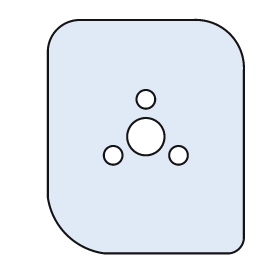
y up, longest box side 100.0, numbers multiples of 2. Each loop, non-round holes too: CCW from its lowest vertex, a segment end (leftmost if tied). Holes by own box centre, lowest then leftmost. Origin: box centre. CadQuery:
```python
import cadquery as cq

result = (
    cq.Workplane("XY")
    .moveTo(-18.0, -50.0)
    .lineTo(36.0, -50.0)
    .threePointArc((40.0, -48.0), (42.0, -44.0))
    .lineTo(42.0, 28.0)
    .threePointArc((36.0, 44.0), (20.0, 50.0))
    .lineTo(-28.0, 50.0)
    .threePointArc((-38.0, 46.0), (-42.0, 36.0))
    .lineTo(-42.0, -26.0)
    .threePointArc((-34.0, -42.0), (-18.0, -50.0))
    .close()
    .moveTo(-14.0, -8.0)
    .circle(4.0)
    .moveTo(14.0, -8.0)
    .circle(4.0)
    .moveTo(0.0, 0.0)
    .circle(8.0)
    .moveTo(0.0, 16.0)
    .circle(4.0)
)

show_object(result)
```